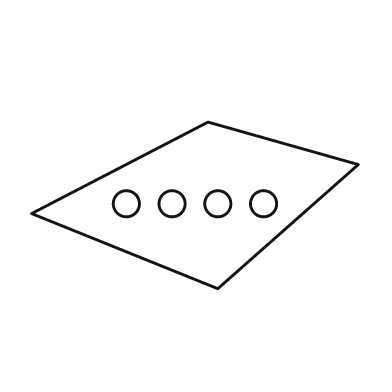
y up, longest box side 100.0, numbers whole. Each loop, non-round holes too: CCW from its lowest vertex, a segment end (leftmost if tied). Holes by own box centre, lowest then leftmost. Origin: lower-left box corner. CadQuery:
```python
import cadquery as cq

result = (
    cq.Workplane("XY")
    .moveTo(57.0, 0.0)
    .lineTo(100.0, 38.0)
    .lineTo(54.0, 51.0)
    .lineTo(0.0, 23.0)
    .close()
    .moveTo(29.0, 26.0)
    .circle(4.0)
    .moveTo(43.0, 26.0)
    .circle(4.0)
    .moveTo(57.0, 26.0)
    .circle(4.0)
    .moveTo(71.0, 26.0)
    .circle(4.0)
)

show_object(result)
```